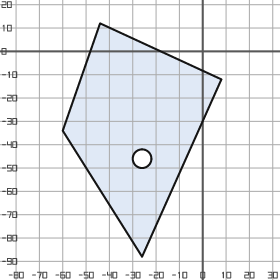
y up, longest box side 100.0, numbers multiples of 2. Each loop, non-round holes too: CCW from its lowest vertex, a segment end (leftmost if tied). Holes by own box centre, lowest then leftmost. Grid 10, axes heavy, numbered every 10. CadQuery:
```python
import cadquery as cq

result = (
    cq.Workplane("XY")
    .moveTo(-26.0, -88.0)
    .lineTo(8.0, -12.0)
    .lineTo(-44.0, 12.0)
    .lineTo(-60.0, -34.0)
    .close()
    .moveTo(-26.0, -46.0)
    .circle(4.0)
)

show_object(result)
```